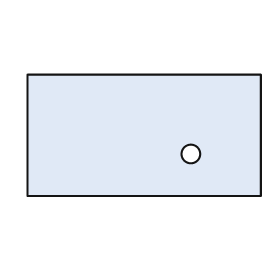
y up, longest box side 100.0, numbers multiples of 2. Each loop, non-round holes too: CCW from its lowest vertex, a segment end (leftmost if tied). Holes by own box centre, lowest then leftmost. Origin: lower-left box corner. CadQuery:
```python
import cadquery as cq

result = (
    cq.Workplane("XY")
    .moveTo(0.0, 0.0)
    .lineTo(100.0, 0.0)
    .lineTo(100.0, 52.0)
    .lineTo(0.0, 52.0)
    .close()
    .moveTo(70.0, 18.0)
    .circle(4.0)
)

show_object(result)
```